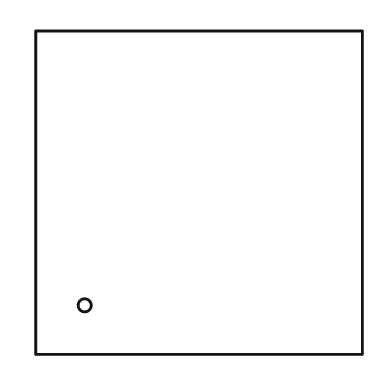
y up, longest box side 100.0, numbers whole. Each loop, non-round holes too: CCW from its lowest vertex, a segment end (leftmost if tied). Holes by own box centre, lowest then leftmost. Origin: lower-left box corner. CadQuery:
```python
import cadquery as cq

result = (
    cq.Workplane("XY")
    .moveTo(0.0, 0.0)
    .lineTo(100.0, 0.0)
    .lineTo(100.0, 99.0)
    .lineTo(0.0, 99.0)
    .close()
    .moveTo(15.0, 15.0)
    .circle(2.0)
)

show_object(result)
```